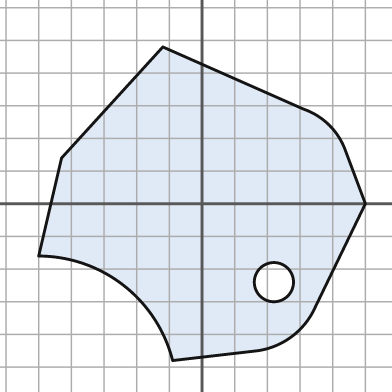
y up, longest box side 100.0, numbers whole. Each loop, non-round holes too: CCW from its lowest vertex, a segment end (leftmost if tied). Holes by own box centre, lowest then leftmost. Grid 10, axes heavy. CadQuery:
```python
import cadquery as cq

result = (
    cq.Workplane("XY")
    .moveTo(-9.0, -48.0)
    .lineTo(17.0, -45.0)
    .threePointArc((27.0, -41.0), (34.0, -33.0))
    .lineTo(50.0, 0.0)
    .lineTo(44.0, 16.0)
    .threePointArc((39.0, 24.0), (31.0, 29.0))
    .lineTo(-12.0, 48.0)
    .lineTo(-43.0, 14.0)
    .lineTo(-50.0, -16.0)
    .threePointArc((-24.0, -25.0), (-9.0, -48.0))
    .close()
    .moveTo(22.0, -24.0)
    .circle(6.0)
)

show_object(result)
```